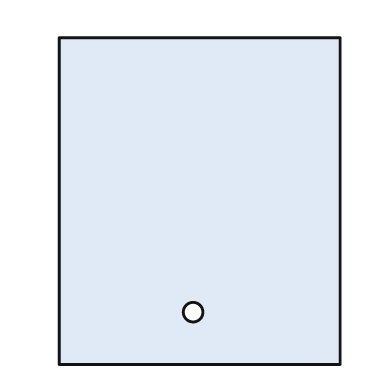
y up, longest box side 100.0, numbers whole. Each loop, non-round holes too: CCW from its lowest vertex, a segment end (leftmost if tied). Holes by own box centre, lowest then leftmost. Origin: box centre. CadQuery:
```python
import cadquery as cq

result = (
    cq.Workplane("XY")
    .moveTo(-43.0, -50.0)
    .lineTo(43.0, -50.0)
    .lineTo(43.0, 50.0)
    .lineTo(-43.0, 50.0)
    .close()
    .moveTo(-2.0, -34.0)
    .circle(3.0)
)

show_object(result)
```